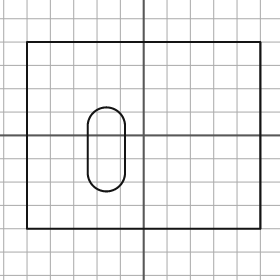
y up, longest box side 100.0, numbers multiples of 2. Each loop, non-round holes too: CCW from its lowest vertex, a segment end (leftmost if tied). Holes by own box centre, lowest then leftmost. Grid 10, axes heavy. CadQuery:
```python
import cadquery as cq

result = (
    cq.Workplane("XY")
    .moveTo(-50.0, -40.0)
    .lineTo(50.0, -40.0)
    .lineTo(50.0, 40.0)
    .lineTo(-50.0, 40.0)
    .close()
    .moveTo(-24.0, -16.0)
    .threePointArc((-16.0, -24.0), (-8.0, -16.0))
    .lineTo(-8.0, 4.0)
    .threePointArc((-16.0, 12.0), (-24.0, 4.0))
    .close()
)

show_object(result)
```